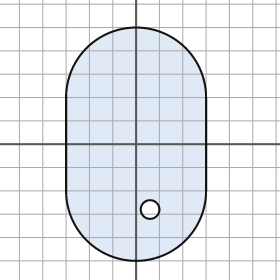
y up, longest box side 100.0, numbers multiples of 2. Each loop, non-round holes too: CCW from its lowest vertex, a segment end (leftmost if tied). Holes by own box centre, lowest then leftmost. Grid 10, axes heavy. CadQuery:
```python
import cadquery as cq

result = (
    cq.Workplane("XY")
    .moveTo(-30.0, -20.0)
    .threePointArc((0.0, -50.0), (30.0, -20.0))
    .lineTo(30.0, 20.0)
    .threePointArc((0.0, 50.0), (-30.0, 20.0))
    .close()
    .moveTo(6.0, -28.0)
    .circle(4.0)
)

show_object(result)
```